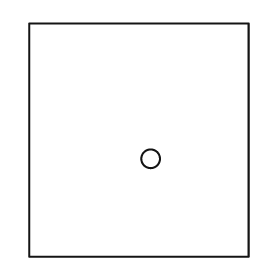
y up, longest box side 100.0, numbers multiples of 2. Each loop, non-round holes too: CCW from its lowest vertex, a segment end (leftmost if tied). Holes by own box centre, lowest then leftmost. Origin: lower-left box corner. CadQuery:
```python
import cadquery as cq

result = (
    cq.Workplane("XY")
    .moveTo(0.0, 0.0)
    .lineTo(94.0, 0.0)
    .lineTo(94.0, 100.0)
    .lineTo(0.0, 100.0)
    .close()
    .moveTo(52.0, 42.0)
    .circle(4.0)
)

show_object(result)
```